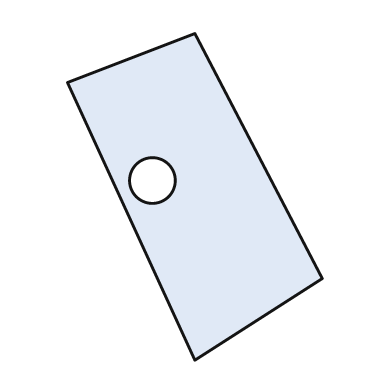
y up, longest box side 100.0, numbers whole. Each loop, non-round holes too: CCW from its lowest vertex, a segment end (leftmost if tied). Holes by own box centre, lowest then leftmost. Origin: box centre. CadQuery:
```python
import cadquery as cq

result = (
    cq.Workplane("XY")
    .moveTo(0.0, -50.0)
    .lineTo(39.0, -25.0)
    .lineTo(0.0, 50.0)
    .lineTo(-39.0, 35.0)
    .close()
    .moveTo(-13.0, 5.0)
    .circle(7.0)
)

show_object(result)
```